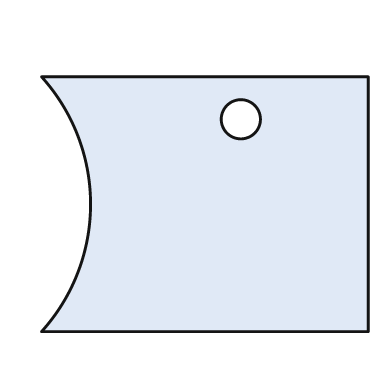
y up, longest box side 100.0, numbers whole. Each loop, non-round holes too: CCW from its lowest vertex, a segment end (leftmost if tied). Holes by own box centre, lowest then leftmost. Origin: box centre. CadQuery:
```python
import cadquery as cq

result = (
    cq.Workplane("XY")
    .moveTo(-50.0, -39.0)
    .lineTo(50.0, -39.0)
    .lineTo(50.0, 39.0)
    .lineTo(-50.0, 39.0)
    .threePointArc((-35.0, 0.0), (-50.0, -39.0))
    .close()
    .moveTo(11.0, 26.0)
    .circle(6.0)
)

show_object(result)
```